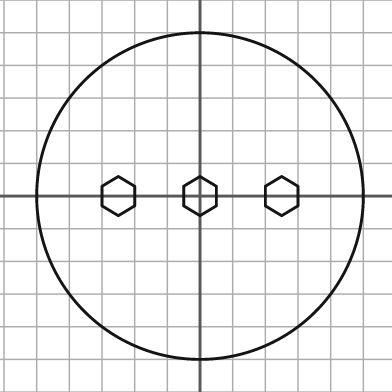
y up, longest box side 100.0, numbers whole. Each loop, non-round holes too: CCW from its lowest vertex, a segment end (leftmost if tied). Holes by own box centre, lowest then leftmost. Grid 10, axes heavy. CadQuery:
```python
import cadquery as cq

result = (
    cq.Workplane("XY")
    .moveTo(0.0, 0.0)
    .circle(50.0)
    .moveTo(-25.0, -6.0)
    .lineTo(-20.0, -3.0)
    .lineTo(-20.0, 3.0)
    .lineTo(-25.0, 6.0)
    .lineTo(-30.0, 3.0)
    .lineTo(-30.0, -3.0)
    .close()
    .moveTo(0.0, -6.0)
    .lineTo(5.0, -3.0)
    .lineTo(5.0, 3.0)
    .lineTo(0.0, 6.0)
    .lineTo(-5.0, 3.0)
    .lineTo(-5.0, -3.0)
    .close()
    .moveTo(25.0, -6.0)
    .lineTo(30.0, -3.0)
    .lineTo(30.0, 3.0)
    .lineTo(25.0, 6.0)
    .lineTo(20.0, 3.0)
    .lineTo(20.0, -3.0)
    .close()
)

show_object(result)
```